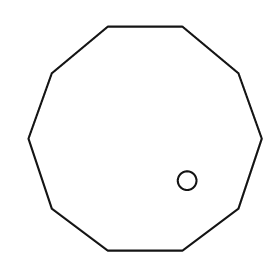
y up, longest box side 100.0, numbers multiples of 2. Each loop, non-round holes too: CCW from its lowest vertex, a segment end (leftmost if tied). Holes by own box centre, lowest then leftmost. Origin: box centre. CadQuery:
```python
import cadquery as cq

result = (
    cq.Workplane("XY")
    .moveTo(-16.0, -48.0)
    .lineTo(16.0, -48.0)
    .lineTo(40.0, -30.0)
    .lineTo(50.0, 0.0)
    .lineTo(40.0, 28.0)
    .lineTo(16.0, 48.0)
    .lineTo(-16.0, 48.0)
    .lineTo(-40.0, 28.0)
    .lineTo(-50.0, 0.0)
    .lineTo(-40.0, -30.0)
    .close()
    .moveTo(18.0, -18.0)
    .circle(4.0)
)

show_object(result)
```